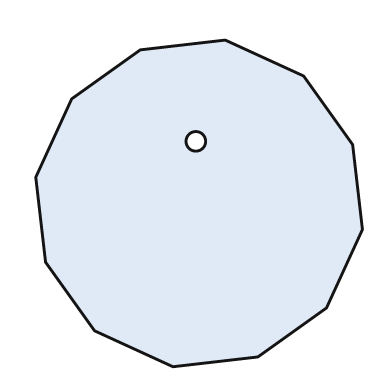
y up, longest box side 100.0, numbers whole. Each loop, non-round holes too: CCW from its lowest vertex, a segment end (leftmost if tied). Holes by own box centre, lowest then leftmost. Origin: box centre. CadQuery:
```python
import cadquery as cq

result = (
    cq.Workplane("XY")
    .moveTo(-8.0, -50.0)
    .lineTo(18.0, -47.0)
    .lineTo(39.0, -32.0)
    .lineTo(50.0, -8.0)
    .lineTo(47.0, 18.0)
    .lineTo(32.0, 39.0)
    .lineTo(8.0, 50.0)
    .lineTo(-18.0, 47.0)
    .lineTo(-39.0, 32.0)
    .lineTo(-50.0, 8.0)
    .lineTo(-47.0, -18.0)
    .lineTo(-32.0, -39.0)
    .close()
    .moveTo(-1.0, 19.0)
    .circle(3.0)
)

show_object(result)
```